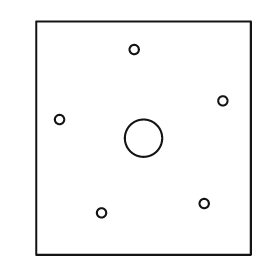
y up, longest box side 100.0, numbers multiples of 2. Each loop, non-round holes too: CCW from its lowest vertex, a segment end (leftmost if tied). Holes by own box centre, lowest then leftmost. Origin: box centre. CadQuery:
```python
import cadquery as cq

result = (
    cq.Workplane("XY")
    .moveTo(-46.0, -50.0)
    .lineTo(46.0, -50.0)
    .lineTo(46.0, 50.0)
    .lineTo(-46.0, 50.0)
    .close()
    .moveTo(-18.0, -32.0)
    .circle(2.0)
    .moveTo(26.0, -28.0)
    .circle(2.0)
    .moveTo(0.0, 0.0)
    .circle(8.0)
    .moveTo(-36.0, 8.0)
    .circle(2.0)
    .moveTo(34.0, 16.0)
    .circle(2.0)
    .moveTo(-4.0, 38.0)
    .circle(2.0)
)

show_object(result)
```